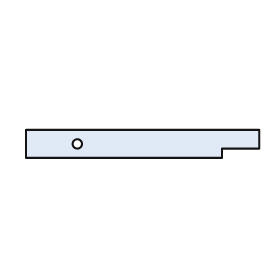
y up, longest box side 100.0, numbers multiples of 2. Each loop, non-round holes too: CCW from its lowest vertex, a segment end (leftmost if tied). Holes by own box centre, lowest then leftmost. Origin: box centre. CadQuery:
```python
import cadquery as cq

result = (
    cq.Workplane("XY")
    .moveTo(-50.0, -6.0)
    .lineTo(34.0, -6.0)
    .lineTo(34.0, -2.0)
    .lineTo(50.0, -2.0)
    .lineTo(50.0, 6.0)
    .lineTo(-50.0, 6.0)
    .close()
    .moveTo(-28.0, 0.0)
    .circle(2.0)
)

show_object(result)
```